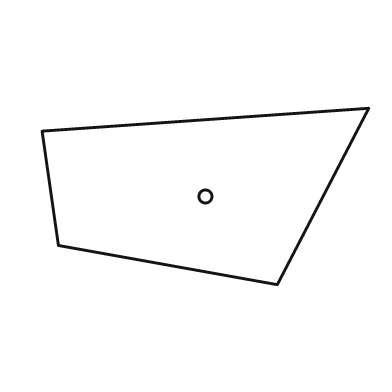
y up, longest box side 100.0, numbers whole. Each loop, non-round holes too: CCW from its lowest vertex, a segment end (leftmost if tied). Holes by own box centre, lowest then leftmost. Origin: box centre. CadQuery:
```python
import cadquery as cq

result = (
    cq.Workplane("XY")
    .moveTo(22.0, -27.0)
    .lineTo(50.0, 27.0)
    .lineTo(-50.0, 20.0)
    .lineTo(-45.0, -15.0)
    .close()
    .moveTo(0.0, 0.0)
    .circle(2.0)
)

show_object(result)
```